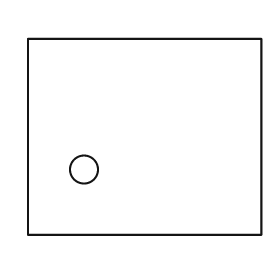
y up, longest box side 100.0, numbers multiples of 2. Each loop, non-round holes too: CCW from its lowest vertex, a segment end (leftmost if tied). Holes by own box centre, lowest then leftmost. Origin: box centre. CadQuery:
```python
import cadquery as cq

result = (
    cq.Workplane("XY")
    .moveTo(-50.0, -42.0)
    .lineTo(50.0, -42.0)
    .lineTo(50.0, 42.0)
    .lineTo(-50.0, 42.0)
    .close()
    .moveTo(-26.0, -14.0)
    .circle(6.0)
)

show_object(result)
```